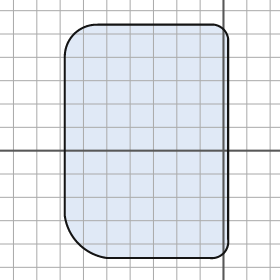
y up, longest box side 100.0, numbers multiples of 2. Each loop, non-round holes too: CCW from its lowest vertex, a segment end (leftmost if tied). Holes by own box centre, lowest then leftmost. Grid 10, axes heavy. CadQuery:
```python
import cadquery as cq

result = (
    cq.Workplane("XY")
    .moveTo(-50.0, -46.0)
    .lineTo(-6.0, -46.0)
    .threePointArc((0.0, -44.0), (2.0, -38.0))
    .lineTo(2.0, 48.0)
    .threePointArc((0.0, 52.0), (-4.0, 54.0))
    .lineTo(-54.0, 54.0)
    .threePointArc((-64.0, 50.0), (-68.0, 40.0))
    .lineTo(-68.0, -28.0)
    .threePointArc((-62.0, -40.0), (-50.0, -46.0))
    .close()
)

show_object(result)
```